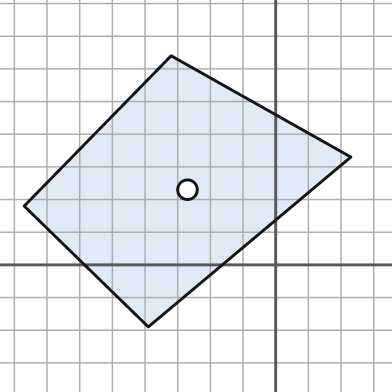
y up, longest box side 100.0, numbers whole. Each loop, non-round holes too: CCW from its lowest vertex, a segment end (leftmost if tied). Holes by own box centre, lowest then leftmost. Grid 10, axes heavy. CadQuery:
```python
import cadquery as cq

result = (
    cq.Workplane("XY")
    .moveTo(-39.0, -19.0)
    .lineTo(23.0, 33.0)
    .lineTo(-32.0, 64.0)
    .lineTo(-77.0, 18.0)
    .close()
    .moveTo(-27.0, 23.0)
    .circle(3.0)
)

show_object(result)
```